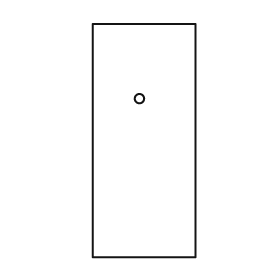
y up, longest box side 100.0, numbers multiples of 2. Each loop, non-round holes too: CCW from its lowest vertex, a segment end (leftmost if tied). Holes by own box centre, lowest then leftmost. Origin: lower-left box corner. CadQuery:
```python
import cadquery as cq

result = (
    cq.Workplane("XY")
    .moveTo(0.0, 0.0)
    .lineTo(44.0, 0.0)
    .lineTo(44.0, 100.0)
    .lineTo(0.0, 100.0)
    .close()
    .moveTo(20.0, 68.0)
    .circle(2.0)
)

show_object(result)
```